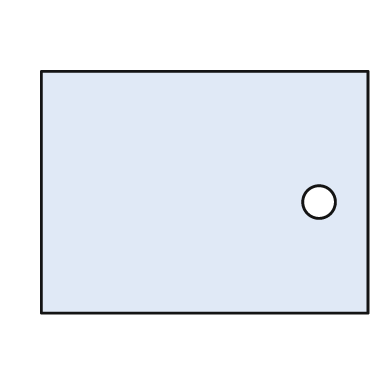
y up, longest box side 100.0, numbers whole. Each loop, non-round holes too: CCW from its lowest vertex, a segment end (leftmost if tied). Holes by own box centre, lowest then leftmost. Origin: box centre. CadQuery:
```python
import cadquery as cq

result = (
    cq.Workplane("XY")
    .moveTo(-50.0, -37.0)
    .lineTo(50.0, -37.0)
    .lineTo(50.0, 37.0)
    .lineTo(-50.0, 37.0)
    .close()
    .moveTo(35.0, -3.0)
    .circle(5.0)
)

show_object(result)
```